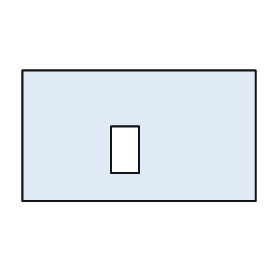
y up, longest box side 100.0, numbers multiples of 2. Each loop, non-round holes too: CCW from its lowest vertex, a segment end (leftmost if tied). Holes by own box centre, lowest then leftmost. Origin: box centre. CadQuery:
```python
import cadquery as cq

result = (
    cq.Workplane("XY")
    .moveTo(-50.0, -28.0)
    .lineTo(50.0, -28.0)
    .lineTo(50.0, 28.0)
    .lineTo(-50.0, 28.0)
    .close()
    .moveTo(-12.0, -16.0)
    .lineTo(0.0, -16.0)
    .lineTo(0.0, 4.0)
    .lineTo(-12.0, 4.0)
    .close()
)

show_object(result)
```